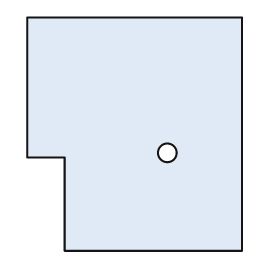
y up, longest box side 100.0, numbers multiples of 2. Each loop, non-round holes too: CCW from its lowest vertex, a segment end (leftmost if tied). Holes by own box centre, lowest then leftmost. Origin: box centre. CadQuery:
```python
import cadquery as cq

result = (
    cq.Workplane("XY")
    .moveTo(-30.0, -50.0)
    .lineTo(46.0, -50.0)
    .lineTo(46.0, 50.0)
    .lineTo(-46.0, 50.0)
    .lineTo(-46.0, -10.0)
    .lineTo(-30.0, -10.0)
    .close()
    .moveTo(14.0, -8.0)
    .circle(4.0)
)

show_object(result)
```